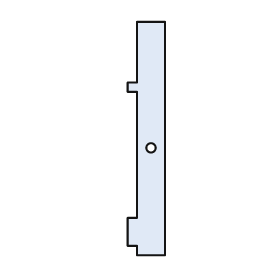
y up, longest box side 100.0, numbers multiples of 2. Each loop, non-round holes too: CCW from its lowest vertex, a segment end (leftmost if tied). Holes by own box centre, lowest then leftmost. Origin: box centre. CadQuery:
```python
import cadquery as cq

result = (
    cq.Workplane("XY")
    .moveTo(-4.0, -50.0)
    .lineTo(8.0, -50.0)
    .lineTo(8.0, 50.0)
    .lineTo(-4.0, 50.0)
    .lineTo(-4.0, 24.0)
    .lineTo(-8.0, 24.0)
    .lineTo(-8.0, 20.0)
    .lineTo(-4.0, 20.0)
    .lineTo(-4.0, -34.0)
    .lineTo(-8.0, -34.0)
    .lineTo(-8.0, -46.0)
    .lineTo(-4.0, -46.0)
    .close()
    .moveTo(2.0, -4.0)
    .circle(2.0)
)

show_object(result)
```